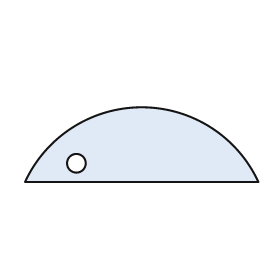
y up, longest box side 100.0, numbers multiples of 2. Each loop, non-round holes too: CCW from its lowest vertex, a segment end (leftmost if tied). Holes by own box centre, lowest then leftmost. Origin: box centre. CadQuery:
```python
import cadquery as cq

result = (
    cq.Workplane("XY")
    .moveTo(-50.0, -16.0)
    .lineTo(50.0, -16.0)
    .threePointArc((0.0, 16.0), (-50.0, -16.0))
    .close()
    .moveTo(-28.0, -8.0)
    .circle(4.0)
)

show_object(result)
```